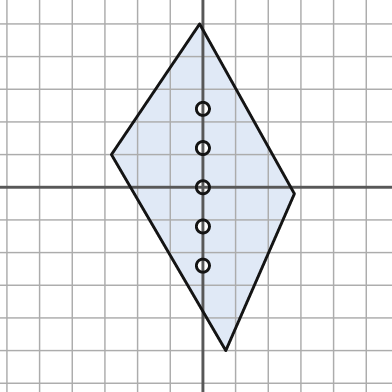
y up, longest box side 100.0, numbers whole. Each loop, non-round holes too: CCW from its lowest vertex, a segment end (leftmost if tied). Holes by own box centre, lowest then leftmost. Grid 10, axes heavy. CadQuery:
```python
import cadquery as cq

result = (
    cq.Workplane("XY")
    .moveTo(7.0, -50.0)
    .lineTo(28.0, -2.0)
    .lineTo(-1.0, 50.0)
    .lineTo(-28.0, 10.0)
    .close()
    .moveTo(0.0, -24.0)
    .circle(2.0)
    .moveTo(0.0, -12.0)
    .circle(2.0)
    .moveTo(0.0, 0.0)
    .circle(2.0)
    .moveTo(0.0, 12.0)
    .circle(2.0)
    .moveTo(0.0, 24.0)
    .circle(2.0)
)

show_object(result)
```